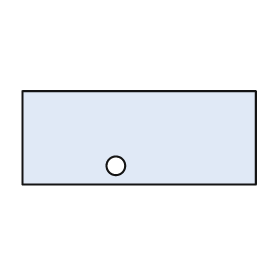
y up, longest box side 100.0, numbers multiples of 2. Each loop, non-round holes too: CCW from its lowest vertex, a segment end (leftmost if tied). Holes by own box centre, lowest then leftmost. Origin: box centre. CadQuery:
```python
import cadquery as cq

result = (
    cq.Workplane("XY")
    .moveTo(-50.0, -20.0)
    .lineTo(50.0, -20.0)
    .lineTo(50.0, 20.0)
    .lineTo(-50.0, 20.0)
    .close()
    .moveTo(-10.0, -12.0)
    .circle(4.0)
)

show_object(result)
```